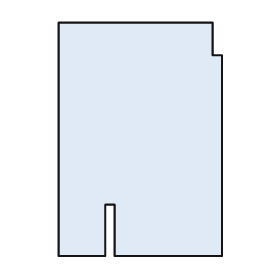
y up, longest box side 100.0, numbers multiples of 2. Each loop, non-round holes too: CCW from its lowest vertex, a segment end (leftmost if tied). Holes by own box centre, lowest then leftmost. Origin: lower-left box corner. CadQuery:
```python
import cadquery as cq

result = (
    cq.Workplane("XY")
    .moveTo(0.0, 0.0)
    .lineTo(20.0, 0.0)
    .lineTo(20.0, 22.0)
    .lineTo(24.0, 22.0)
    .lineTo(24.0, 0.0)
    .lineTo(70.0, 0.0)
    .lineTo(70.0, 86.0)
    .lineTo(66.0, 86.0)
    .lineTo(66.0, 100.0)
    .lineTo(0.0, 100.0)
    .close()
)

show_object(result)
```